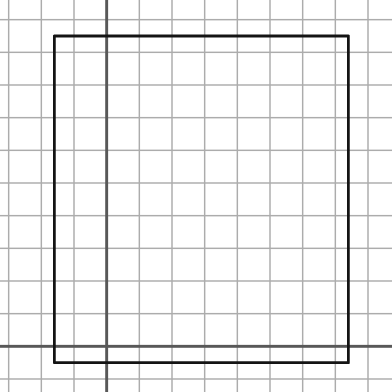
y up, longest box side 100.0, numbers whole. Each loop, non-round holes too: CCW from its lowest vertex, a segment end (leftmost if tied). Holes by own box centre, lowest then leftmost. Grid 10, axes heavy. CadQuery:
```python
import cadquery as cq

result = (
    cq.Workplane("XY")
    .moveTo(-16.0, -5.0)
    .lineTo(74.0, -5.0)
    .lineTo(74.0, 95.0)
    .lineTo(-16.0, 95.0)
    .close()
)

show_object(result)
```